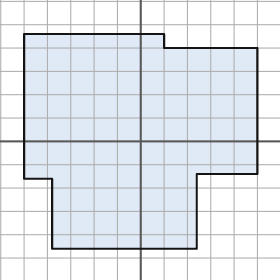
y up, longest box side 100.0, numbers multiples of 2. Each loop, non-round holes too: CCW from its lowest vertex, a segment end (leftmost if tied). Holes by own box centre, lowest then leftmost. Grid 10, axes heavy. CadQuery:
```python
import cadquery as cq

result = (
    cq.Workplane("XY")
    .moveTo(-38.0, -46.0)
    .lineTo(24.0, -46.0)
    .lineTo(24.0, -14.0)
    .lineTo(50.0, -14.0)
    .lineTo(50.0, 40.0)
    .lineTo(10.0, 40.0)
    .lineTo(10.0, 46.0)
    .lineTo(-50.0, 46.0)
    .lineTo(-50.0, -16.0)
    .lineTo(-38.0, -16.0)
    .close()
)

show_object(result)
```